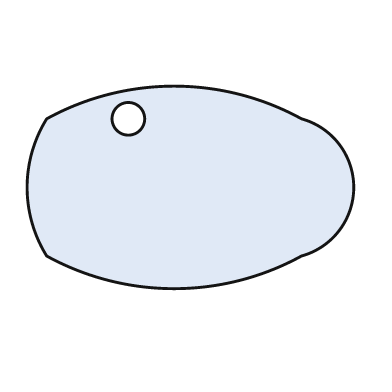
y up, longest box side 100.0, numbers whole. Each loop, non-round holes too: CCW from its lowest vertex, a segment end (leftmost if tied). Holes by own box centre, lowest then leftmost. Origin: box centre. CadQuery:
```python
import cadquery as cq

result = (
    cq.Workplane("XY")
    .moveTo(-44.0, -21.0)
    .threePointArc((-5.0, -31.0), (34.0, -21.0))
    .threePointArc((50.0, 0.0), (34.0, 21.0))
    .threePointArc((-5.0, 31.0), (-44.0, 21.0))
    .threePointArc((-50.0, 0.0), (-44.0, -21.0))
    .close()
    .moveTo(-19.0, 21.0)
    .circle(5.0)
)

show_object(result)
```